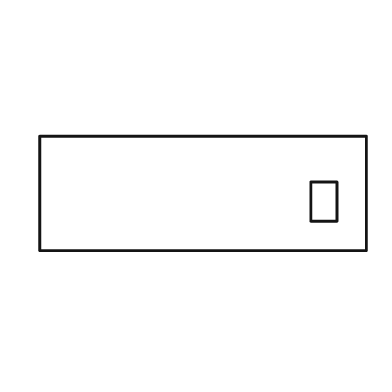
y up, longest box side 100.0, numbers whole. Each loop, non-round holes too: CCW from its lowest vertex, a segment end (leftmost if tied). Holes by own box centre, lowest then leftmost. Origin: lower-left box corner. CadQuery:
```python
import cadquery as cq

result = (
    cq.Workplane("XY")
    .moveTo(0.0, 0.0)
    .lineTo(100.0, 0.0)
    .lineTo(100.0, 35.0)
    .lineTo(0.0, 35.0)
    .close()
    .moveTo(83.0, 9.0)
    .lineTo(91.0, 9.0)
    .lineTo(91.0, 21.0)
    .lineTo(83.0, 21.0)
    .close()
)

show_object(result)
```